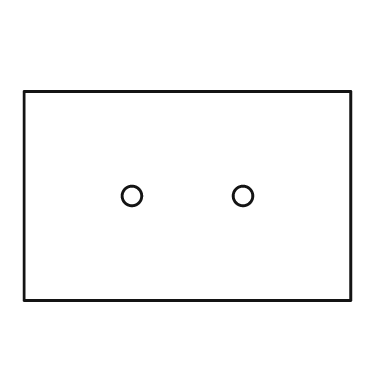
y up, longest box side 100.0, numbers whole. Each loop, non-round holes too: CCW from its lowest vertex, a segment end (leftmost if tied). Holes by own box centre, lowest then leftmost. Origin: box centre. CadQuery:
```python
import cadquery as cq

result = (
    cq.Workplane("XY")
    .moveTo(-50.0, -32.0)
    .lineTo(50.0, -32.0)
    .lineTo(50.0, 32.0)
    .lineTo(-50.0, 32.0)
    .close()
    .moveTo(-17.0, 0.0)
    .circle(3.0)
    .moveTo(17.0, 0.0)
    .circle(3.0)
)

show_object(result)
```